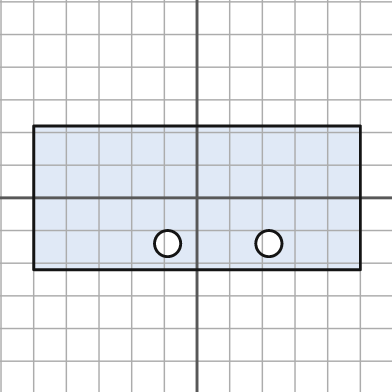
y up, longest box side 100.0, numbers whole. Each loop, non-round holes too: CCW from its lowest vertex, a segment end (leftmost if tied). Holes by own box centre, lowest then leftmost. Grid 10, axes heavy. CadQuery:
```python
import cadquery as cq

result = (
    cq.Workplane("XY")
    .moveTo(-50.0, -22.0)
    .lineTo(50.0, -22.0)
    .lineTo(50.0, 22.0)
    .lineTo(-50.0, 22.0)
    .close()
    .moveTo(-9.0, -14.0)
    .circle(4.0)
    .moveTo(22.0, -14.0)
    .circle(4.0)
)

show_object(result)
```